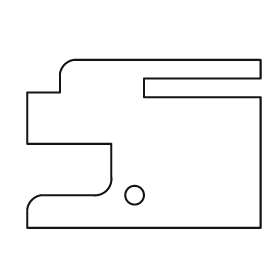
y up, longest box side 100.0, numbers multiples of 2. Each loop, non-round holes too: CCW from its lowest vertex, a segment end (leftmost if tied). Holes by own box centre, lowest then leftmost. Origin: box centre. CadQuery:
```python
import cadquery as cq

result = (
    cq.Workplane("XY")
    .moveTo(-50.0, -36.0)
    .lineTo(50.0, -36.0)
    .lineTo(50.0, 20.0)
    .lineTo(0.0, 20.0)
    .lineTo(0.0, 28.0)
    .lineTo(50.0, 28.0)
    .lineTo(50.0, 36.0)
    .lineTo(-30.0, 36.0)
    .threePointArc((-34.0, 34.0), (-36.0, 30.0))
    .lineTo(-36.0, 22.0)
    .lineTo(-50.0, 22.0)
    .lineTo(-50.0, 0.0)
    .lineTo(-14.0, 0.0)
    .lineTo(-14.0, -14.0)
    .threePointArc((-16.0, -20.0), (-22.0, -22.0))
    .lineTo(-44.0, -22.0)
    .threePointArc((-48.0, -24.0), (-50.0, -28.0))
    .close()
    .moveTo(-4.0, -22.0)
    .circle(4.0)
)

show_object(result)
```